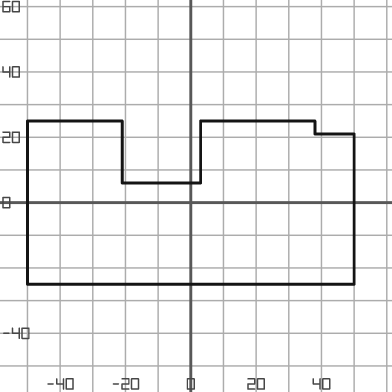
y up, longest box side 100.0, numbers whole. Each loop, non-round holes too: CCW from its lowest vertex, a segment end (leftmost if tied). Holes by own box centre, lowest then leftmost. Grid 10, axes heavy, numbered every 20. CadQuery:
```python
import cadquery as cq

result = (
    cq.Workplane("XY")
    .moveTo(-50.0, -25.0)
    .lineTo(50.0, -25.0)
    .lineTo(50.0, 21.0)
    .lineTo(38.0, 21.0)
    .lineTo(38.0, 25.0)
    .lineTo(3.0, 25.0)
    .lineTo(3.0, 6.0)
    .lineTo(-21.0, 6.0)
    .lineTo(-21.0, 25.0)
    .lineTo(-50.0, 25.0)
    .close()
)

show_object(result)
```